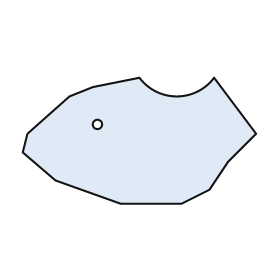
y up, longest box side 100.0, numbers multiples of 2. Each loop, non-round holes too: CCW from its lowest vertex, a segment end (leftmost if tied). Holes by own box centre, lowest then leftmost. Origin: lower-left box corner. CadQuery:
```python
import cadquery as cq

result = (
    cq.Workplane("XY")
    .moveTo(42.0, 0.0)
    .lineTo(68.0, 0.0)
    .lineTo(80.0, 6.0)
    .lineTo(88.0, 18.0)
    .lineTo(100.0, 30.0)
    .lineTo(82.0, 54.0)
    .threePointArc((66.0, 46.0), (50.0, 54.0))
    .lineTo(30.0, 50.0)
    .lineTo(20.0, 46.0)
    .lineTo(2.0, 30.0)
    .lineTo(0.0, 22.0)
    .lineTo(14.0, 10.0)
    .close()
    .moveTo(32.0, 34.0)
    .circle(2.0)
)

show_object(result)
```